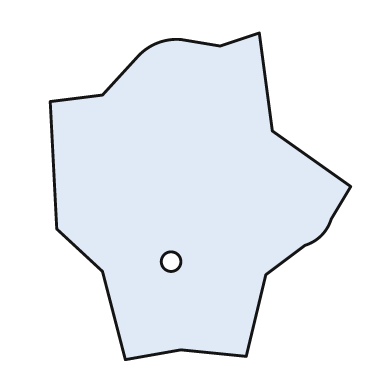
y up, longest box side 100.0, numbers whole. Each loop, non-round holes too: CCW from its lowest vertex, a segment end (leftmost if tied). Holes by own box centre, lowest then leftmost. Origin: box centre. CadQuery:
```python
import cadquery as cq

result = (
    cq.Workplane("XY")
    .moveTo(-23.0, -50.0)
    .lineTo(-6.0, -47.0)
    .lineTo(14.0, -49.0)
    .lineTo(20.0, -24.0)
    .lineTo(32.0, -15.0)
    .threePointArc((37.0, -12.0), (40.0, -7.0))
    .lineTo(46.0, 3.0)
    .lineTo(22.0, 20.0)
    .lineTo(18.0, 50.0)
    .lineTo(6.0, 46.0)
    .lineTo(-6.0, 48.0)
    .threePointArc((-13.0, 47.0), (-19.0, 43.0))
    .lineTo(-30.0, 31.0)
    .lineTo(-46.0, 29.0)
    .lineTo(-44.0, -10.0)
    .lineTo(-30.0, -23.0)
    .close()
    .moveTo(-9.0, -20.0)
    .circle(3.0)
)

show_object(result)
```